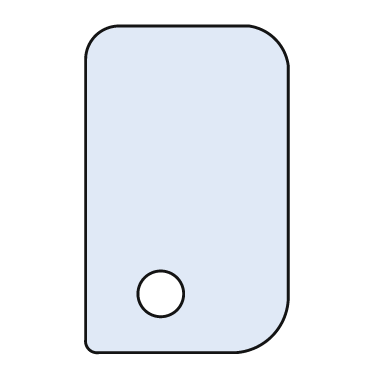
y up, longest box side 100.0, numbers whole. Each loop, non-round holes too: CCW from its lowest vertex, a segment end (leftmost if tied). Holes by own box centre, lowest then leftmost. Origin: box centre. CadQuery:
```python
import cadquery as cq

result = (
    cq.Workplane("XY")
    .moveTo(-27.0, -50.0)
    .lineTo(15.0, -50.0)
    .threePointArc((26.0, -45.0), (31.0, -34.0))
    .lineTo(31.0, 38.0)
    .threePointArc((27.0, 46.0), (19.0, 50.0))
    .lineTo(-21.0, 50.0)
    .threePointArc((-28.0, 47.0), (-31.0, 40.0))
    .lineTo(-31.0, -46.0)
    .threePointArc((-30.0, -49.0), (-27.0, -50.0))
    .close()
    .moveTo(-8.0, -32.0)
    .circle(7.0)
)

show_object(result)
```